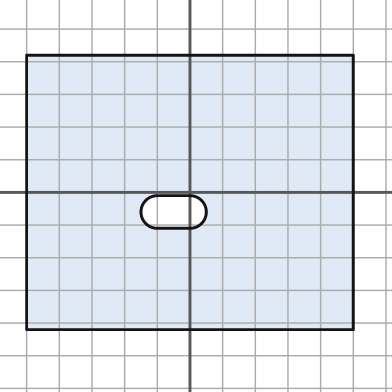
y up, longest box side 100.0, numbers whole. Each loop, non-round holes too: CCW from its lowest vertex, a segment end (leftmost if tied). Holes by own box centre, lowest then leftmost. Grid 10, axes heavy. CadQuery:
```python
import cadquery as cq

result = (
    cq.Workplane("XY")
    .moveTo(-50.0, -42.0)
    .lineTo(50.0, -42.0)
    .lineTo(50.0, 42.0)
    .lineTo(-50.0, 42.0)
    .close()
    .moveTo(-10.0, -11.0)
    .lineTo(0.0, -11.0)
    .threePointArc((5.0, -6.0), (0.0, -1.0))
    .lineTo(-10.0, -1.0)
    .threePointArc((-15.0, -6.0), (-10.0, -11.0))
    .close()
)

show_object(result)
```